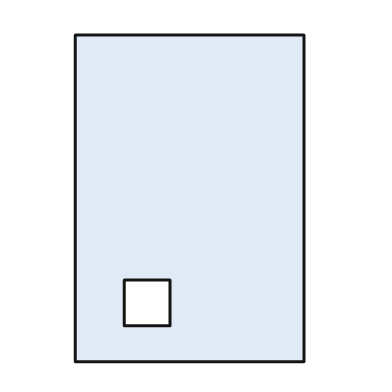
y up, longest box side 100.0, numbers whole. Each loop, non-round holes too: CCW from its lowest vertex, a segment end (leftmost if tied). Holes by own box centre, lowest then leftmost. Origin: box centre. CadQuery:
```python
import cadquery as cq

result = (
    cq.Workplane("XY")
    .moveTo(-35.0, -50.0)
    .lineTo(35.0, -50.0)
    .lineTo(35.0, 50.0)
    .lineTo(-35.0, 50.0)
    .close()
    .moveTo(-20.0, -39.0)
    .lineTo(-6.0, -39.0)
    .lineTo(-6.0, -25.0)
    .lineTo(-20.0, -25.0)
    .close()
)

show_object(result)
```